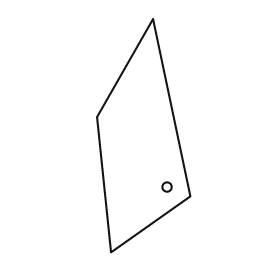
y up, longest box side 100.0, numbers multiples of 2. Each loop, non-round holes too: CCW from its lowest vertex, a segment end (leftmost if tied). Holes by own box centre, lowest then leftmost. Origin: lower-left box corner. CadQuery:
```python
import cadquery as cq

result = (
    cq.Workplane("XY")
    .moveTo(6.0, 0.0)
    .lineTo(40.0, 24.0)
    .lineTo(24.0, 100.0)
    .lineTo(0.0, 58.0)
    .close()
    .moveTo(30.0, 28.0)
    .circle(2.0)
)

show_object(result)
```